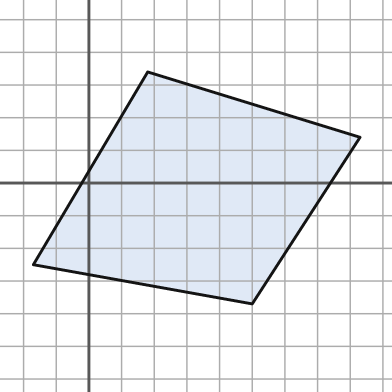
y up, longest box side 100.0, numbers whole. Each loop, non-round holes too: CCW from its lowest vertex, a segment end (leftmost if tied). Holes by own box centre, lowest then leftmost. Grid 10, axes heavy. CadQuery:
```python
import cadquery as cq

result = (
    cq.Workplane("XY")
    .moveTo(50.0, -37.0)
    .lineTo(83.0, 14.0)
    .lineTo(18.0, 34.0)
    .lineTo(-17.0, -25.0)
    .close()
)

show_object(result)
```